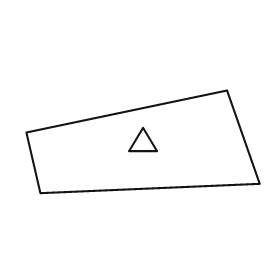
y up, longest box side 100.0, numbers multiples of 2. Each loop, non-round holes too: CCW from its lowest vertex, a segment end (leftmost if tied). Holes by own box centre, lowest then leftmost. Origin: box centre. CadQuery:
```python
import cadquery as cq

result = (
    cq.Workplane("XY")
    .moveTo(-44.0, -22.0)
    .lineTo(50.0, -18.0)
    .lineTo(36.0, 22.0)
    .lineTo(-50.0, 4.0)
    .close()
    .moveTo(-6.0, -4.0)
    .lineTo(6.0, -4.0)
    .lineTo(0.0, 6.0)
    .close()
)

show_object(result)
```